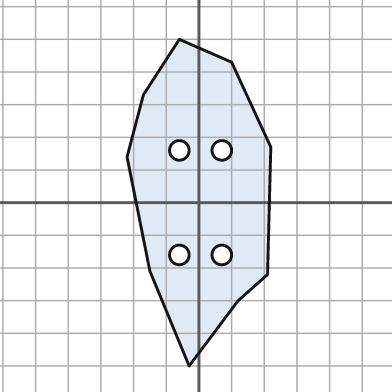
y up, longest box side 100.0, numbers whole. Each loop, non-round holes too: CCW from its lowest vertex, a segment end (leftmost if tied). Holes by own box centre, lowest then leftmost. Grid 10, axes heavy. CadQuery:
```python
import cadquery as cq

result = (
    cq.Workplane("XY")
    .moveTo(-3.0, -50.0)
    .lineTo(12.0, -30.0)
    .lineTo(21.0, -22.0)
    .lineTo(22.0, 17.0)
    .lineTo(10.0, 43.0)
    .lineTo(-6.0, 50.0)
    .lineTo(-17.0, 33.0)
    .lineTo(-22.0, 14.0)
    .lineTo(-15.0, -21.0)
    .close()
    .moveTo(-6.0, -16.0)
    .circle(3.0)
    .moveTo(7.0, -16.0)
    .circle(3.0)
    .moveTo(-6.0, 16.0)
    .circle(3.0)
    .moveTo(7.0, 16.0)
    .circle(3.0)
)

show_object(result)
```